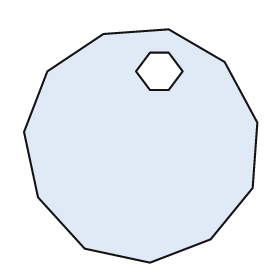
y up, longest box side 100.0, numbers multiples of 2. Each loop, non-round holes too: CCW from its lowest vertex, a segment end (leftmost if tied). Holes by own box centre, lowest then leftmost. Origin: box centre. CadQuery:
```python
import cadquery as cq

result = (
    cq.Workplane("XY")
    .moveTo(4.0, -50.0)
    .lineTo(30.0, -40.0)
    .lineTo(48.0, -18.0)
    .lineTo(50.0, 10.0)
    .lineTo(36.0, 36.0)
    .lineTo(12.0, 50.0)
    .lineTo(-16.0, 48.0)
    .lineTo(-40.0, 32.0)
    .lineTo(-50.0, 6.0)
    .lineTo(-44.0, -22.0)
    .lineTo(-24.0, -44.0)
    .close()
    .moveTo(4.0, 24.0)
    .lineTo(12.0, 24.0)
    .lineTo(18.0, 32.0)
    .lineTo(12.0, 40.0)
    .lineTo(4.0, 40.0)
    .lineTo(-2.0, 32.0)
    .close()
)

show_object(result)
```